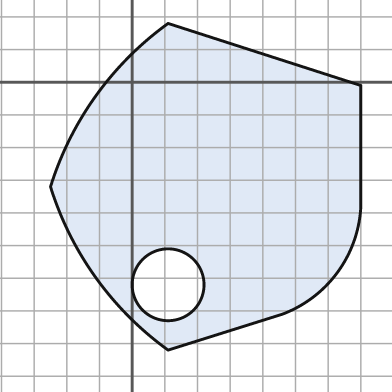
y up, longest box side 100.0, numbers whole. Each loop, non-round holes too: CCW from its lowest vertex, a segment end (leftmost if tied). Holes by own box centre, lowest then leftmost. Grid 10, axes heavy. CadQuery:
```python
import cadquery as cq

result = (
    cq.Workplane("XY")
    .moveTo(11.0, -82.0)
    .lineTo(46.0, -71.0)
    .threePointArc((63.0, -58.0), (70.0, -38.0))
    .lineTo(70.0, -1.0)
    .lineTo(11.0, 18.0)
    .threePointArc((-11.0, -4.0), (-25.0, -32.0))
    .threePointArc((-11.0, -60.0), (11.0, -82.0))
    .close()
    .moveTo(11.0, -62.0)
    .circle(11.0)
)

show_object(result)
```